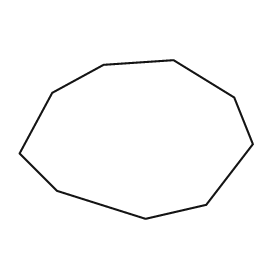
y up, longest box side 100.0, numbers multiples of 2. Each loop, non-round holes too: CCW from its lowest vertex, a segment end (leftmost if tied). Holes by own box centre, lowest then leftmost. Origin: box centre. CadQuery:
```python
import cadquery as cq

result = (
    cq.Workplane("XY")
    .moveTo(4.0, -34.0)
    .lineTo(30.0, -28.0)
    .lineTo(50.0, -2.0)
    .lineTo(42.0, 18.0)
    .lineTo(16.0, 34.0)
    .lineTo(-14.0, 32.0)
    .lineTo(-36.0, 20.0)
    .lineTo(-50.0, -6.0)
    .lineTo(-34.0, -22.0)
    .close()
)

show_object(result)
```